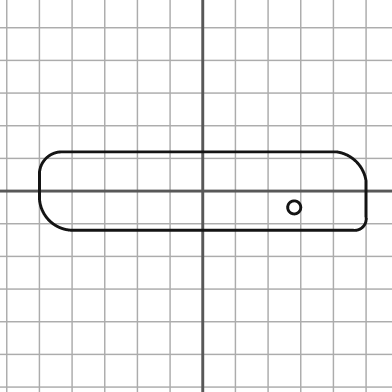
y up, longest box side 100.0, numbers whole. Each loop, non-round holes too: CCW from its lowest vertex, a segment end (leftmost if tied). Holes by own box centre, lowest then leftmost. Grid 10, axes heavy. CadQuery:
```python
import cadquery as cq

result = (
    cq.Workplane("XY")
    .moveTo(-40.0, -12.0)
    .lineTo(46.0, -12.0)
    .threePointArc((49.0, -11.0), (50.0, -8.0))
    .lineTo(50.0, 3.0)
    .threePointArc((47.0, 9.0), (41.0, 12.0))
    .lineTo(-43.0, 12.0)
    .threePointArc((-48.0, 10.0), (-50.0, 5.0))
    .lineTo(-50.0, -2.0)
    .threePointArc((-47.0, -9.0), (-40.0, -12.0))
    .close()
    .moveTo(28.0, -5.0)
    .circle(2.0)
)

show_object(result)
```